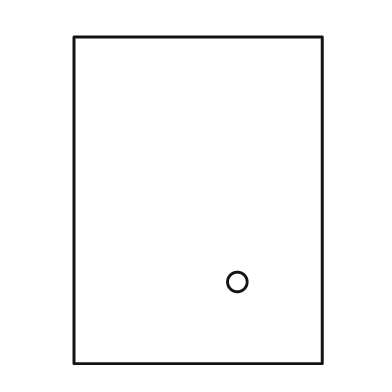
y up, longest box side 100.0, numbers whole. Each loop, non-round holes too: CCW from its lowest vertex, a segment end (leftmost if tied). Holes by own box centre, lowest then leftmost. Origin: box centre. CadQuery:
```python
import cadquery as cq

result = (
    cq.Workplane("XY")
    .moveTo(-38.0, -50.0)
    .lineTo(38.0, -50.0)
    .lineTo(38.0, 50.0)
    .lineTo(-38.0, 50.0)
    .close()
    .moveTo(12.0, -25.0)
    .circle(3.0)
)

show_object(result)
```